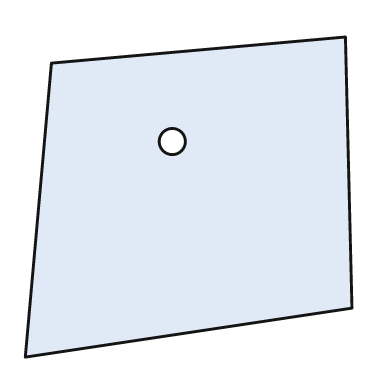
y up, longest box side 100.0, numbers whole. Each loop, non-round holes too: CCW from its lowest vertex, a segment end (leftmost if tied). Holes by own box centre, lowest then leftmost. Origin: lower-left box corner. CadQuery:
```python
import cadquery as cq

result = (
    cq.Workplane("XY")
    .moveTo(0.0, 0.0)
    .lineTo(100.0, 15.0)
    .lineTo(98.0, 98.0)
    .lineTo(8.0, 90.0)
    .close()
    .moveTo(45.0, 66.0)
    .circle(4.0)
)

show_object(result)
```